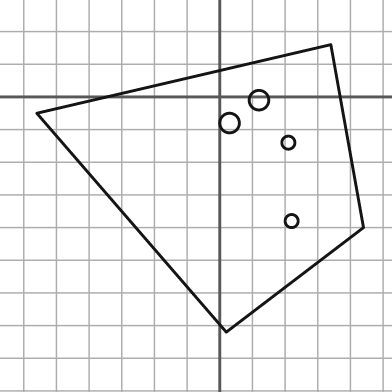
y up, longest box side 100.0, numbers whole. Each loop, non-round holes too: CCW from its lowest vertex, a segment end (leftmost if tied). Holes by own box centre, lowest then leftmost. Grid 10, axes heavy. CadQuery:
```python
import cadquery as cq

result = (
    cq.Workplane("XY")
    .moveTo(2.0, -72.0)
    .lineTo(44.0, -40.0)
    .lineTo(34.0, 16.0)
    .lineTo(-56.0, -5.0)
    .close()
    .moveTo(22.0, -38.0)
    .circle(2.0)
    .moveTo(21.0, -14.0)
    .circle(2.0)
    .moveTo(3.0, -8.0)
    .circle(3.0)
    .moveTo(12.0, -1.0)
    .circle(3.0)
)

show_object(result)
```